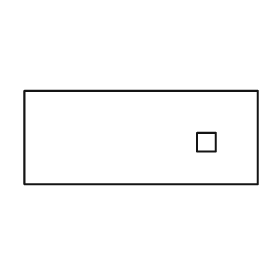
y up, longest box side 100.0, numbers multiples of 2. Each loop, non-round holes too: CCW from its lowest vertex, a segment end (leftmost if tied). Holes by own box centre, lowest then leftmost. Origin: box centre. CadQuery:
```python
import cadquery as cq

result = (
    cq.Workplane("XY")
    .moveTo(-50.0, -20.0)
    .lineTo(50.0, -20.0)
    .lineTo(50.0, 20.0)
    .lineTo(-50.0, 20.0)
    .close()
    .moveTo(24.0, -6.0)
    .lineTo(32.0, -6.0)
    .lineTo(32.0, 2.0)
    .lineTo(24.0, 2.0)
    .close()
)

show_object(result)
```